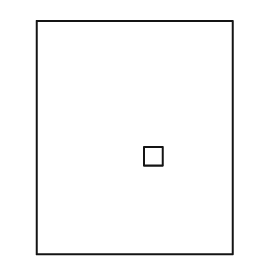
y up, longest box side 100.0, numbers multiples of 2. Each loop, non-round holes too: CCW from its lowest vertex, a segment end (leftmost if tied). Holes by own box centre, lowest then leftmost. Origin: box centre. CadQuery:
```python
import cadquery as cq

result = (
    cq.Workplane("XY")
    .moveTo(-42.0, -50.0)
    .lineTo(42.0, -50.0)
    .lineTo(42.0, 50.0)
    .lineTo(-42.0, 50.0)
    .close()
    .moveTo(4.0, -12.0)
    .lineTo(12.0, -12.0)
    .lineTo(12.0, -4.0)
    .lineTo(4.0, -4.0)
    .close()
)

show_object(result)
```